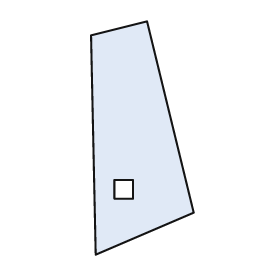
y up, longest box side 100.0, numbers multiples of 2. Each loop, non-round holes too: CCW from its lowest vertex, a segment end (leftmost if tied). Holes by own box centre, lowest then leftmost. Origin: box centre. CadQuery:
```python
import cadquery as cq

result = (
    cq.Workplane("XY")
    .moveTo(-20.0, -50.0)
    .lineTo(22.0, -32.0)
    .lineTo(2.0, 50.0)
    .lineTo(-22.0, 44.0)
    .close()
    .moveTo(-12.0, -26.0)
    .lineTo(-4.0, -26.0)
    .lineTo(-4.0, -18.0)
    .lineTo(-12.0, -18.0)
    .close()
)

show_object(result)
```